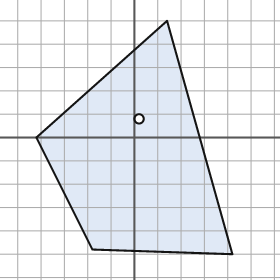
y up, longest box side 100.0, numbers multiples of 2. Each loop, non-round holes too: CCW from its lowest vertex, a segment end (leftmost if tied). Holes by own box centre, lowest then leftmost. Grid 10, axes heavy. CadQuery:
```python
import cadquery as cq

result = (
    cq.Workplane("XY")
    .moveTo(42.0, -50.0)
    .lineTo(14.0, 50.0)
    .lineTo(-42.0, 0.0)
    .lineTo(-18.0, -48.0)
    .close()
    .moveTo(2.0, 8.0)
    .circle(2.0)
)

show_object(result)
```